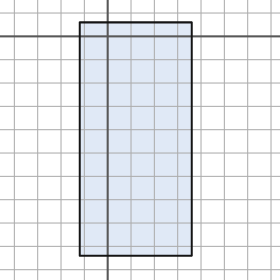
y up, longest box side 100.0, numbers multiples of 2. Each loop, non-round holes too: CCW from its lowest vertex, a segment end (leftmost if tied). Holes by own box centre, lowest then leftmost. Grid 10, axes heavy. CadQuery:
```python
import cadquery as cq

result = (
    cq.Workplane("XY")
    .moveTo(-12.0, -94.0)
    .lineTo(36.0, -94.0)
    .lineTo(36.0, 6.0)
    .lineTo(-12.0, 6.0)
    .close()
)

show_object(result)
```